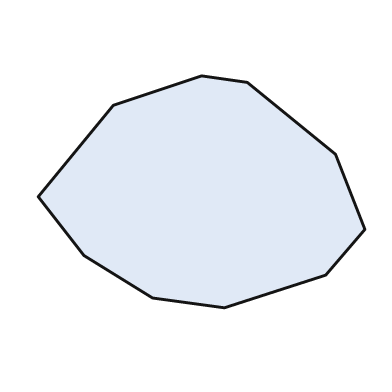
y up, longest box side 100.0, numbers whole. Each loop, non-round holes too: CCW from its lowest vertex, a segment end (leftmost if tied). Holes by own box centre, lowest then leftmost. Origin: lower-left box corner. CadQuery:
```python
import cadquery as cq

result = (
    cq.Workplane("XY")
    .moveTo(57.0, 0.0)
    .lineTo(88.0, 10.0)
    .lineTo(100.0, 24.0)
    .lineTo(91.0, 47.0)
    .lineTo(64.0, 69.0)
    .lineTo(50.0, 71.0)
    .lineTo(23.0, 62.0)
    .lineTo(0.0, 34.0)
    .lineTo(14.0, 16.0)
    .lineTo(35.0, 3.0)
    .close()
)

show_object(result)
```